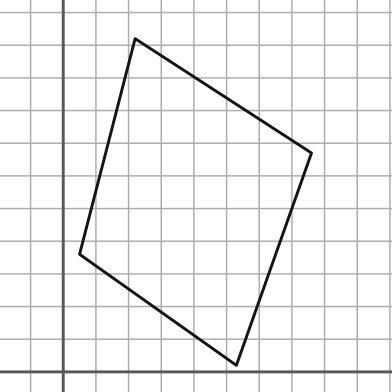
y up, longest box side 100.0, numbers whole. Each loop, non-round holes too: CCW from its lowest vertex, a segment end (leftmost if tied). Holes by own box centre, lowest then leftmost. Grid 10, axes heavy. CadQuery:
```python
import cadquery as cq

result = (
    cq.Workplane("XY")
    .moveTo(53.0, 2.0)
    .lineTo(76.0, 67.0)
    .lineTo(22.0, 102.0)
    .lineTo(5.0, 36.0)
    .close()
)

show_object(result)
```